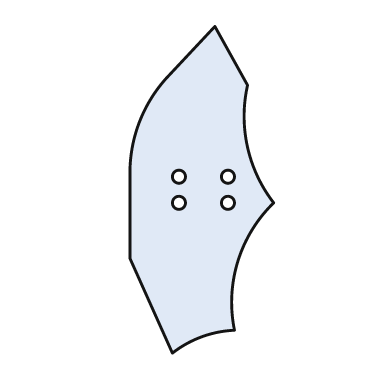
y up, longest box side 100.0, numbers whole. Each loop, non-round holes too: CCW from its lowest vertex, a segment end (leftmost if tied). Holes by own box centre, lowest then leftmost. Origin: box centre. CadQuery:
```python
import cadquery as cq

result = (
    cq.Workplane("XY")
    .moveTo(-9.0, -50.0)
    .threePointArc((0.0, -45.0), (10.0, -43.0))
    .threePointArc((11.0, -22.0), (22.0, -4.0))
    .threePointArc((14.0, 13.0), (14.0, 32.0))
    .lineTo(4.0, 50.0)
    .lineTo(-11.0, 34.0)
    .threePointArc((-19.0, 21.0), (-22.0, 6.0))
    .lineTo(-22.0, -21.0)
    .close()
    .moveTo(-7.0, -4.0)
    .circle(2.0)
    .moveTo(8.0, -4.0)
    .circle(2.0)
    .moveTo(-7.0, 4.0)
    .circle(2.0)
    .moveTo(8.0, 4.0)
    .circle(2.0)
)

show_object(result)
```